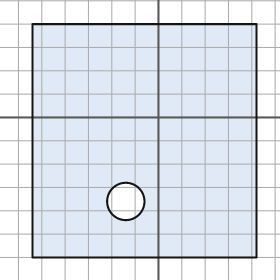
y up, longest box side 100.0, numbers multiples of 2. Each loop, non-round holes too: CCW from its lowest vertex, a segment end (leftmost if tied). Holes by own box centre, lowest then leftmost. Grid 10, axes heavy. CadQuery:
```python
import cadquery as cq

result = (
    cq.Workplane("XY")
    .moveTo(-54.0, -60.0)
    .lineTo(42.0, -60.0)
    .lineTo(42.0, 40.0)
    .lineTo(-54.0, 40.0)
    .close()
    .moveTo(-14.0, -36.0)
    .circle(8.0)
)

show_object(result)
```